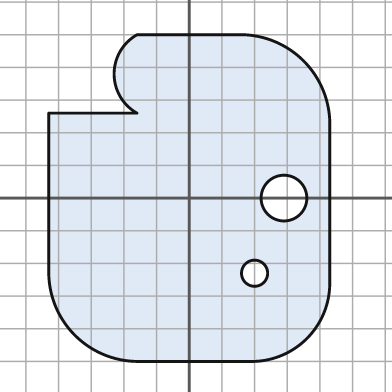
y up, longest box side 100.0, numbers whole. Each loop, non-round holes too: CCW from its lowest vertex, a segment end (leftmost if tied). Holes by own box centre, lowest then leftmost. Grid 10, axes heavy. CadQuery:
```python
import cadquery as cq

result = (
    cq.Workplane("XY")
    .moveTo(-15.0, -50.0)
    .lineTo(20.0, -50.0)
    .threePointArc((36.0, -43.0), (43.0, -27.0))
    .lineTo(43.0, 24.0)
    .threePointArc((35.0, 42.0), (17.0, 50.0))
    .lineTo(-16.0, 50.0)
    .threePointArc((-23.0, 38.0), (-16.0, 26.0))
    .lineTo(-43.0, 26.0)
    .lineTo(-43.0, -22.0)
    .threePointArc((-35.0, -42.0), (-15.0, -50.0))
    .close()
    .moveTo(20.0, -23.0)
    .circle(4.0)
    .moveTo(29.0, 0.0)
    .circle(7.0)
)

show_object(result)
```